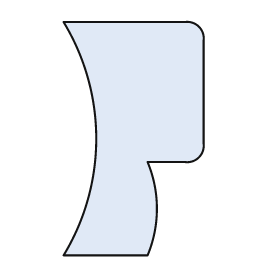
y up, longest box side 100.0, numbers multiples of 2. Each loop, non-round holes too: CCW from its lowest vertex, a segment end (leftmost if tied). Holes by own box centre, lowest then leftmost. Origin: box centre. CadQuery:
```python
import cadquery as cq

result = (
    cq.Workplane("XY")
    .moveTo(-30.0, -50.0)
    .lineTo(6.0, -50.0)
    .threePointArc((10.0, -30.0), (6.0, -10.0))
    .lineTo(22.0, -10.0)
    .threePointArc((28.0, -8.0), (30.0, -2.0))
    .lineTo(30.0, 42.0)
    .threePointArc((28.0, 48.0), (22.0, 50.0))
    .lineTo(-30.0, 50.0)
    .threePointArc((-16.0, 0.0), (-30.0, -50.0))
    .close()
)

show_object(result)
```